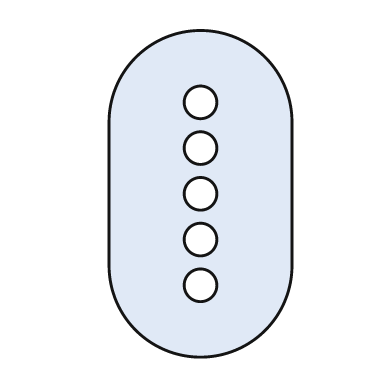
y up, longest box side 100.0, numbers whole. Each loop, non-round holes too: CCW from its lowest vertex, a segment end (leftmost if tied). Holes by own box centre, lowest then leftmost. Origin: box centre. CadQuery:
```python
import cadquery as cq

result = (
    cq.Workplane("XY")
    .moveTo(-28.0, -22.0)
    .threePointArc((0.0, -50.0), (28.0, -22.0))
    .lineTo(28.0, 22.0)
    .threePointArc((0.0, 50.0), (-28.0, 22.0))
    .close()
    .moveTo(0.0, -28.0)
    .circle(5.0)
    .moveTo(0.0, -14.0)
    .circle(5.0)
    .moveTo(0.0, 0.0)
    .circle(5.0)
    .moveTo(0.0, 14.0)
    .circle(5.0)
    .moveTo(0.0, 28.0)
    .circle(5.0)
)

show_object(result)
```